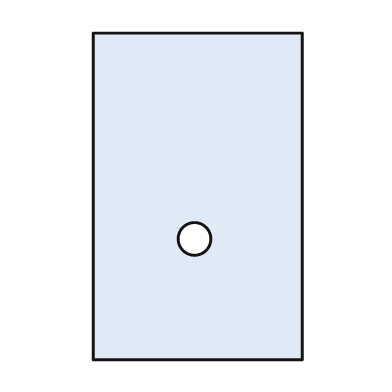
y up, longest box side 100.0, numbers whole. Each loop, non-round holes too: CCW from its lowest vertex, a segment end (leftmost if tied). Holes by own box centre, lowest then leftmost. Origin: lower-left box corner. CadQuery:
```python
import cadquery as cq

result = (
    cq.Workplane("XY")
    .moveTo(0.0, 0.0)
    .lineTo(64.0, 0.0)
    .lineTo(64.0, 100.0)
    .lineTo(0.0, 100.0)
    .close()
    .moveTo(31.0, 37.0)
    .circle(5.0)
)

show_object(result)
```